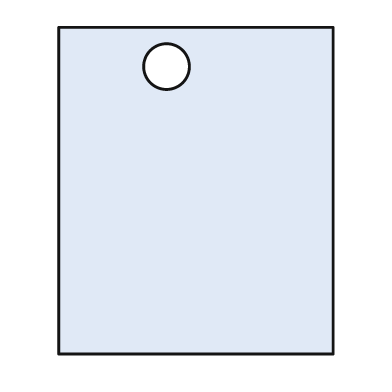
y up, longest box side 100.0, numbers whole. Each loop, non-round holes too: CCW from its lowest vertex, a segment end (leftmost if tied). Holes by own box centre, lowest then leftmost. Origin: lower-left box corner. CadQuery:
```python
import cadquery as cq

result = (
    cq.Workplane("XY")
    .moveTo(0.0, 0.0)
    .lineTo(84.0, 0.0)
    .lineTo(84.0, 100.0)
    .lineTo(0.0, 100.0)
    .close()
    .moveTo(33.0, 88.0)
    .circle(7.0)
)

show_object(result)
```